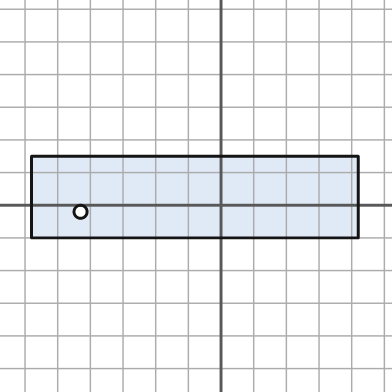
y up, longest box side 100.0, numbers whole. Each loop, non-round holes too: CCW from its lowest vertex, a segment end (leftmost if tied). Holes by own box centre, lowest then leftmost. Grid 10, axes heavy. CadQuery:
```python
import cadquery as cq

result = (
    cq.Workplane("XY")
    .moveTo(-58.0, -10.0)
    .lineTo(42.0, -10.0)
    .lineTo(42.0, 15.0)
    .lineTo(-58.0, 15.0)
    .close()
    .moveTo(-43.0, -2.0)
    .circle(2.0)
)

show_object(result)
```